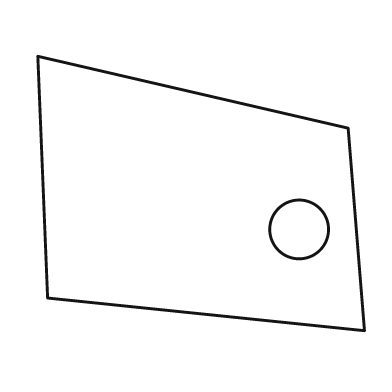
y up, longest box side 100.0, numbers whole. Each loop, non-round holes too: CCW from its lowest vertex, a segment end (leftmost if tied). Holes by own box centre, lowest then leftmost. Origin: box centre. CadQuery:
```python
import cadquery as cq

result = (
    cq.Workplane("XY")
    .moveTo(50.0, -42.0)
    .lineTo(45.0, 20.0)
    .lineTo(-50.0, 42.0)
    .lineTo(-47.0, -32.0)
    .close()
    .moveTo(30.0, -11.0)
    .circle(9.0)
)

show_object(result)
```